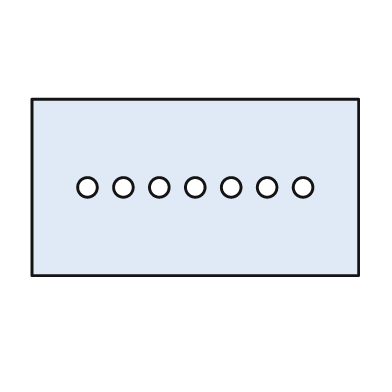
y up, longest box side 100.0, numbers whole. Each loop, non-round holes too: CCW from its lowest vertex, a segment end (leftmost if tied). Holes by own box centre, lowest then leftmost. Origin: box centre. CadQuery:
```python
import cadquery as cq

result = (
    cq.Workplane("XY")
    .moveTo(-50.0, -27.0)
    .lineTo(50.0, -27.0)
    .lineTo(50.0, 27.0)
    .lineTo(-50.0, 27.0)
    .close()
    .moveTo(-33.0, 0.0)
    .circle(3.0)
    .moveTo(-22.0, 0.0)
    .circle(3.0)
    .moveTo(-11.0, 0.0)
    .circle(3.0)
    .moveTo(0.0, 0.0)
    .circle(3.0)
    .moveTo(11.0, 0.0)
    .circle(3.0)
    .moveTo(22.0, 0.0)
    .circle(3.0)
    .moveTo(33.0, 0.0)
    .circle(3.0)
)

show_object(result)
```